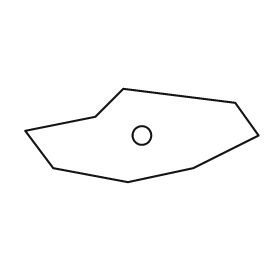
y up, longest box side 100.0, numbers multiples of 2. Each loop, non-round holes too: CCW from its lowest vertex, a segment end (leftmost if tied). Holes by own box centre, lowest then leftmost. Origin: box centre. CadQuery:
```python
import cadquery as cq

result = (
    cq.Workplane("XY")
    .moveTo(-6.0, -20.0)
    .lineTo(22.0, -14.0)
    .lineTo(50.0, 0.0)
    .lineTo(40.0, 14.0)
    .lineTo(-8.0, 20.0)
    .lineTo(-20.0, 8.0)
    .lineTo(-50.0, 2.0)
    .lineTo(-38.0, -14.0)
    .close()
    .moveTo(0.0, 0.0)
    .circle(4.0)
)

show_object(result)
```